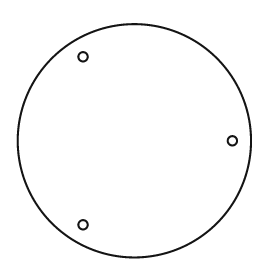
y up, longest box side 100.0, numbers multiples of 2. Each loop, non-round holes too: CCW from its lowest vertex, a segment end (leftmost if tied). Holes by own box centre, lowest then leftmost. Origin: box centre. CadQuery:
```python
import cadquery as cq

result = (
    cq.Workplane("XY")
    .moveTo(0.0, 0.0)
    .circle(50.0)
    .moveTo(-22.0, -36.0)
    .circle(2.0)
    .moveTo(42.0, 0.0)
    .circle(2.0)
    .moveTo(-22.0, 36.0)
    .circle(2.0)
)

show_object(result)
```